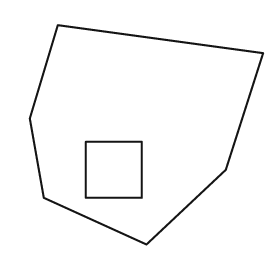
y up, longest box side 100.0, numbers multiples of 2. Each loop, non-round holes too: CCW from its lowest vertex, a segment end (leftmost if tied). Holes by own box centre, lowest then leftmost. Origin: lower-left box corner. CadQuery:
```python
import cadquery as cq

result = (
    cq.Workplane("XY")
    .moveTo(50.0, 0.0)
    .lineTo(84.0, 32.0)
    .lineTo(100.0, 82.0)
    .lineTo(12.0, 94.0)
    .lineTo(0.0, 54.0)
    .lineTo(6.0, 20.0)
    .close()
    .moveTo(24.0, 20.0)
    .lineTo(48.0, 20.0)
    .lineTo(48.0, 44.0)
    .lineTo(24.0, 44.0)
    .close()
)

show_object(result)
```